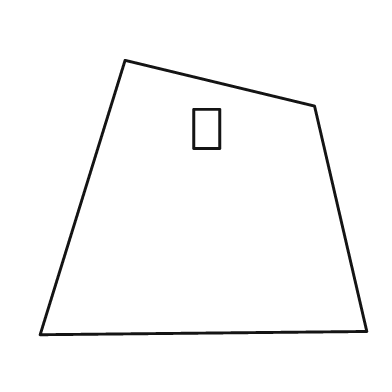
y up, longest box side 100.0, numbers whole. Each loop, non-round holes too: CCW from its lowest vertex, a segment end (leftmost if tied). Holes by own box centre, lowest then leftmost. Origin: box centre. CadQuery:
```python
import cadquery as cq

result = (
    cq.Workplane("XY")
    .moveTo(-50.0, -42.0)
    .lineTo(50.0, -41.0)
    .lineTo(34.0, 28.0)
    .lineTo(-24.0, 42.0)
    .close()
    .moveTo(-3.0, 15.0)
    .lineTo(5.0, 15.0)
    .lineTo(5.0, 27.0)
    .lineTo(-3.0, 27.0)
    .close()
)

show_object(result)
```